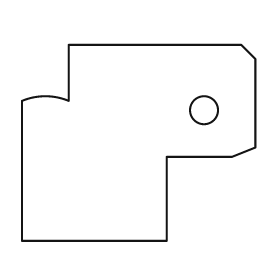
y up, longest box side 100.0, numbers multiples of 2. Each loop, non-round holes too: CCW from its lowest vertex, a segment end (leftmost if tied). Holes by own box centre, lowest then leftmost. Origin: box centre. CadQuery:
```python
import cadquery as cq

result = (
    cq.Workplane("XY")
    .moveTo(-50.0, -42.0)
    .lineTo(12.0, -42.0)
    .lineTo(12.0, -6.0)
    .lineTo(40.0, -6.0)
    .lineTo(50.0, -2.0)
    .lineTo(50.0, 36.0)
    .lineTo(44.0, 42.0)
    .lineTo(-30.0, 42.0)
    .lineTo(-30.0, 18.0)
    .threePointArc((-40.0, 20.0), (-50.0, 18.0))
    .close()
    .moveTo(28.0, 14.0)
    .circle(6.0)
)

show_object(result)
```